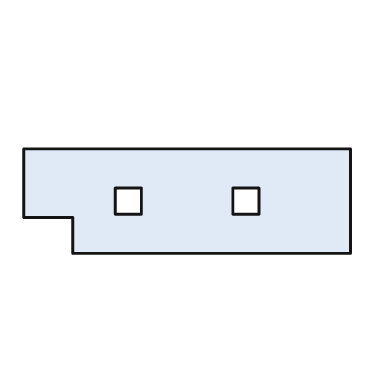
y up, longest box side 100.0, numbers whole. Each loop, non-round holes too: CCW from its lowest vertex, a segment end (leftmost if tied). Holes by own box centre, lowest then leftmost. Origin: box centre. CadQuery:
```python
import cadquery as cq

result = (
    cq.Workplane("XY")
    .moveTo(-35.0, -16.0)
    .lineTo(50.0, -16.0)
    .lineTo(50.0, 16.0)
    .lineTo(-50.0, 16.0)
    .lineTo(-50.0, -5.0)
    .lineTo(-35.0, -5.0)
    .close()
    .moveTo(-22.0, -4.0)
    .lineTo(-14.0, -4.0)
    .lineTo(-14.0, 4.0)
    .lineTo(-22.0, 4.0)
    .close()
    .moveTo(14.0, -4.0)
    .lineTo(22.0, -4.0)
    .lineTo(22.0, 4.0)
    .lineTo(14.0, 4.0)
    .close()
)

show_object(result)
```